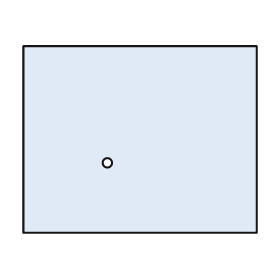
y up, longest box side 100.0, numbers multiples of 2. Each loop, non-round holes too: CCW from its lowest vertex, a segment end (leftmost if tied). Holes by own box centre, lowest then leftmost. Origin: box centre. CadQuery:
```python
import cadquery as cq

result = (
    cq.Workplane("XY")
    .moveTo(-50.0, -40.0)
    .lineTo(50.0, -40.0)
    .lineTo(50.0, 40.0)
    .lineTo(-50.0, 40.0)
    .close()
    .moveTo(-14.0, -10.0)
    .circle(2.0)
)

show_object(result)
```